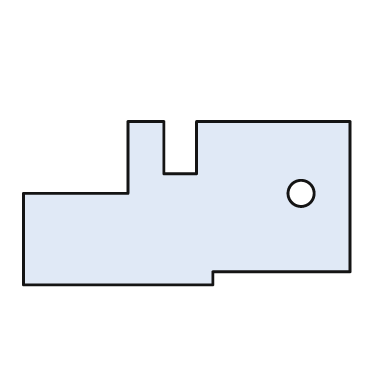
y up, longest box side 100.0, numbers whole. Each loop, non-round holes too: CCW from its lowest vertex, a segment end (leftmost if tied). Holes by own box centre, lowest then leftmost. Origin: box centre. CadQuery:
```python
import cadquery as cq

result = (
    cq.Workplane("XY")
    .moveTo(-50.0, -25.0)
    .lineTo(8.0, -25.0)
    .lineTo(8.0, -21.0)
    .lineTo(50.0, -21.0)
    .lineTo(50.0, 25.0)
    .lineTo(3.0, 25.0)
    .lineTo(3.0, 9.0)
    .lineTo(-7.0, 9.0)
    .lineTo(-7.0, 25.0)
    .lineTo(-18.0, 25.0)
    .lineTo(-18.0, 3.0)
    .lineTo(-50.0, 3.0)
    .close()
    .moveTo(35.0, 3.0)
    .circle(4.0)
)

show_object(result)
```